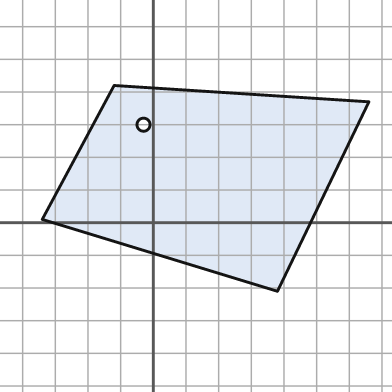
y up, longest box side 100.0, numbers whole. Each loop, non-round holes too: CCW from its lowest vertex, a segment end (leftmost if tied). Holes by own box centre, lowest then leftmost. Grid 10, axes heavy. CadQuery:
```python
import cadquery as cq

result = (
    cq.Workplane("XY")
    .moveTo(38.0, -21.0)
    .lineTo(66.0, 37.0)
    .lineTo(-12.0, 42.0)
    .lineTo(-34.0, 1.0)
    .close()
    .moveTo(-3.0, 30.0)
    .circle(2.0)
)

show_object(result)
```